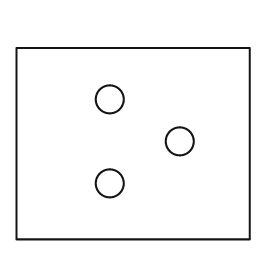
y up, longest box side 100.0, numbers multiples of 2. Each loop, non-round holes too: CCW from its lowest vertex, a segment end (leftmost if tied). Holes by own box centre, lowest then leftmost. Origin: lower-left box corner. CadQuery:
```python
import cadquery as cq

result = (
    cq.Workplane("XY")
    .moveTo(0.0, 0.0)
    .lineTo(100.0, 0.0)
    .lineTo(100.0, 82.0)
    .lineTo(0.0, 82.0)
    .close()
    .moveTo(40.0, 24.0)
    .circle(6.0)
    .moveTo(70.0, 42.0)
    .circle(6.0)
    .moveTo(40.0, 60.0)
    .circle(6.0)
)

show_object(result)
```